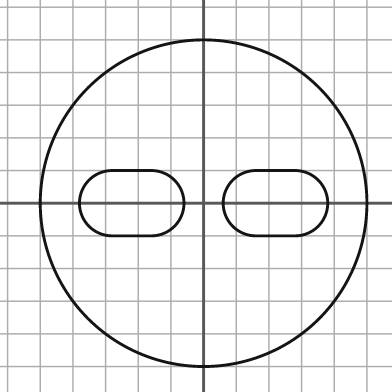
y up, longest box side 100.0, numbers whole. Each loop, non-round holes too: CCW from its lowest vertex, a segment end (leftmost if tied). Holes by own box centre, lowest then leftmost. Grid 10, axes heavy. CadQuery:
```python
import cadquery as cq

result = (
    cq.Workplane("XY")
    .moveTo(0.0, 0.0)
    .circle(50.0)
    .moveTo(-28.0, -10.0)
    .lineTo(-16.0, -10.0)
    .threePointArc((-6.0, 0.0), (-16.0, 10.0))
    .lineTo(-28.0, 10.0)
    .threePointArc((-38.0, 0.0), (-28.0, -10.0))
    .close()
    .moveTo(16.0, -10.0)
    .lineTo(28.0, -10.0)
    .threePointArc((38.0, 0.0), (28.0, 10.0))
    .lineTo(16.0, 10.0)
    .threePointArc((6.0, 0.0), (16.0, -10.0))
    .close()
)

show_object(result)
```